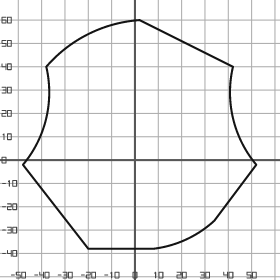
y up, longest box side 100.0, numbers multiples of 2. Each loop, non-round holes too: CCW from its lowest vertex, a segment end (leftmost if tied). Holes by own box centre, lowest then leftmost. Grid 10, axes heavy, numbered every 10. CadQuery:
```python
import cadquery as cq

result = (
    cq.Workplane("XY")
    .moveTo(-20.0, -38.0)
    .lineTo(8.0, -38.0)
    .threePointArc((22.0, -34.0), (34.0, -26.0))
    .lineTo(52.0, -2.0)
    .threePointArc((42.0, 18.0), (42.0, 40.0))
    .lineTo(2.0, 60.0)
    .threePointArc((-20.0, 54.0), (-38.0, 40.0))
    .threePointArc((-38.0, 18.0), (-48.0, -2.0))
    .close()
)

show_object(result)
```